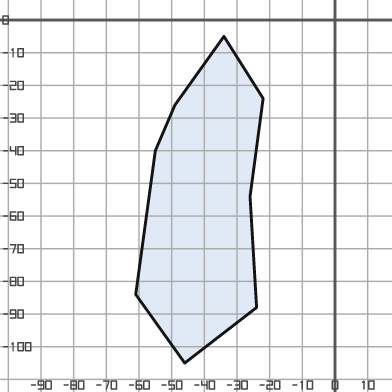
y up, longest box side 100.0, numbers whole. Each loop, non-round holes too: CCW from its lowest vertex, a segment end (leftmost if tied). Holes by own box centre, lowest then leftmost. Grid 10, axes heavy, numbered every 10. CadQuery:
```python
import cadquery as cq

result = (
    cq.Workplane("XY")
    .moveTo(-46.0, -105.0)
    .lineTo(-24.0, -88.0)
    .lineTo(-26.0, -54.0)
    .lineTo(-22.0, -24.0)
    .lineTo(-34.0, -5.0)
    .lineTo(-49.0, -26.0)
    .lineTo(-55.0, -40.0)
    .lineTo(-61.0, -84.0)
    .close()
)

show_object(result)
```